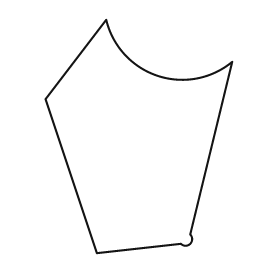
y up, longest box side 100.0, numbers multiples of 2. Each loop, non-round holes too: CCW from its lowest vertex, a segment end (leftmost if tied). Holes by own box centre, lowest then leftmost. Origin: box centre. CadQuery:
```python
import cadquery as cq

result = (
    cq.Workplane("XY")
    .moveTo(-18.0, -50.0)
    .lineTo(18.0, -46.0)
    .threePointArc((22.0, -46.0), (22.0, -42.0))
    .lineTo(40.0, 32.0)
    .threePointArc((8.0, 26.0), (-14.0, 50.0))
    .lineTo(-40.0, 16.0)
    .close()
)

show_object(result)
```